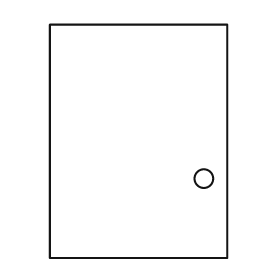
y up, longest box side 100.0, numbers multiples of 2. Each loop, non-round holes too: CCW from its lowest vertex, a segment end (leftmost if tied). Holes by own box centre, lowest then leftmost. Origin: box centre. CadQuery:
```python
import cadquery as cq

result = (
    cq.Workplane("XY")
    .moveTo(-38.0, -50.0)
    .lineTo(38.0, -50.0)
    .lineTo(38.0, 50.0)
    .lineTo(-38.0, 50.0)
    .close()
    .moveTo(28.0, -16.0)
    .circle(4.0)
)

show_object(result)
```